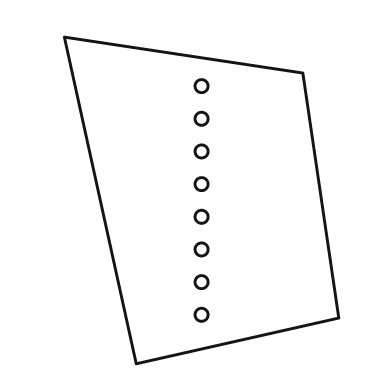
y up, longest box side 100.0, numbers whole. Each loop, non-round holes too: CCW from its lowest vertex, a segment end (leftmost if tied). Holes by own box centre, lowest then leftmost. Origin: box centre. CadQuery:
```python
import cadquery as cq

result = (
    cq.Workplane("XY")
    .moveTo(-20.0, -50.0)
    .lineTo(42.0, -36.0)
    .lineTo(31.0, 39.0)
    .lineTo(-42.0, 50.0)
    .close()
    .moveTo(0.0, -35.0)
    .circle(2.0)
    .moveTo(0.0, -25.0)
    .circle(2.0)
    .moveTo(0.0, -15.0)
    .circle(2.0)
    .moveTo(0.0, -5.0)
    .circle(2.0)
    .moveTo(0.0, 5.0)
    .circle(2.0)
    .moveTo(0.0, 15.0)
    .circle(2.0)
    .moveTo(0.0, 25.0)
    .circle(2.0)
    .moveTo(0.0, 35.0)
    .circle(2.0)
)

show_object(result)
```